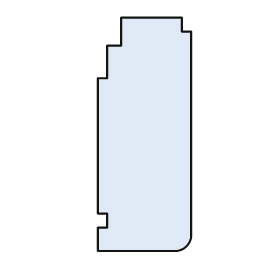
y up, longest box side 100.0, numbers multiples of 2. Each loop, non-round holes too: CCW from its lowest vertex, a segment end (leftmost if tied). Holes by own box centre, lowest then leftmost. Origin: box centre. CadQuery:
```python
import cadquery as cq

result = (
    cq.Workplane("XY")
    .moveTo(-20.0, -50.0)
    .lineTo(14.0, -50.0)
    .threePointArc((18.0, -48.0), (20.0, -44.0))
    .lineTo(20.0, 44.0)
    .lineTo(16.0, 44.0)
    .lineTo(16.0, 50.0)
    .lineTo(-10.0, 50.0)
    .lineTo(-10.0, 38.0)
    .lineTo(-16.0, 38.0)
    .lineTo(-16.0, 24.0)
    .lineTo(-20.0, 24.0)
    .lineTo(-20.0, -34.0)
    .lineTo(-16.0, -34.0)
    .lineTo(-16.0, -40.0)
    .lineTo(-20.0, -40.0)
    .close()
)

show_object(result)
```